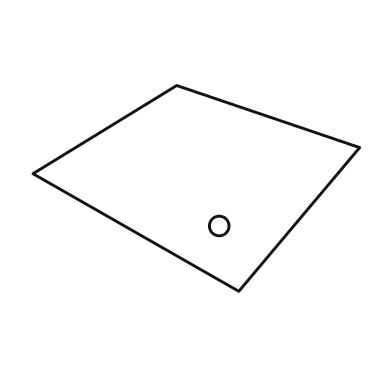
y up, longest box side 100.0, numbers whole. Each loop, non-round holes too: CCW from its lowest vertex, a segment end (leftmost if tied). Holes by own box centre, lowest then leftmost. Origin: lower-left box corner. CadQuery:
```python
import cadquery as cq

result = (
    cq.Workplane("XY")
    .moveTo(63.0, 0.0)
    .lineTo(100.0, 44.0)
    .lineTo(44.0, 63.0)
    .lineTo(0.0, 36.0)
    .close()
    .moveTo(57.0, 20.0)
    .circle(3.0)
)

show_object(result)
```